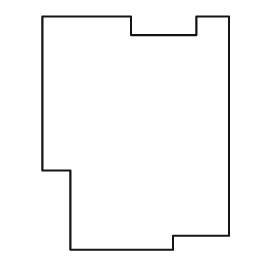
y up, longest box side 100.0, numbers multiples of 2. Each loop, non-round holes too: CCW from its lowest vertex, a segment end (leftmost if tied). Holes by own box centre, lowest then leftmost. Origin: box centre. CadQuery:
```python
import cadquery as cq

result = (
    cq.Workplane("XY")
    .moveTo(-28.0, -50.0)
    .lineTo(16.0, -50.0)
    .lineTo(16.0, -44.0)
    .lineTo(40.0, -44.0)
    .lineTo(40.0, 50.0)
    .lineTo(26.0, 50.0)
    .lineTo(26.0, 42.0)
    .lineTo(-2.0, 42.0)
    .lineTo(-2.0, 50.0)
    .lineTo(-40.0, 50.0)
    .lineTo(-40.0, -16.0)
    .lineTo(-28.0, -16.0)
    .close()
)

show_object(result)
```